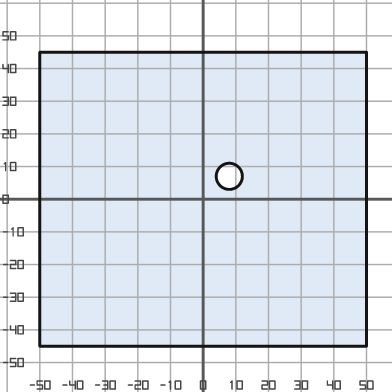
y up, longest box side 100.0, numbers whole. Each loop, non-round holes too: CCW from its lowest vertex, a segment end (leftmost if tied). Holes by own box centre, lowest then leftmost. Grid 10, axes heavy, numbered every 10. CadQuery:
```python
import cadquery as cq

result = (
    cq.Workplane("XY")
    .moveTo(-50.0, -45.0)
    .lineTo(50.0, -45.0)
    .lineTo(50.0, 45.0)
    .lineTo(-50.0, 45.0)
    .close()
    .moveTo(8.0, 7.0)
    .circle(4.0)
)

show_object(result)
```